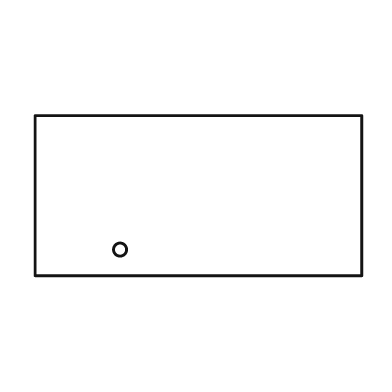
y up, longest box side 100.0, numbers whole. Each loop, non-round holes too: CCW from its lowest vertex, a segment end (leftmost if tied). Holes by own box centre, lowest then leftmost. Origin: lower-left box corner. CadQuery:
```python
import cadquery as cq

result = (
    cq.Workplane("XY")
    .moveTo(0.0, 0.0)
    .lineTo(100.0, 0.0)
    .lineTo(100.0, 49.0)
    .lineTo(0.0, 49.0)
    .close()
    .moveTo(26.0, 8.0)
    .circle(2.0)
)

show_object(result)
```